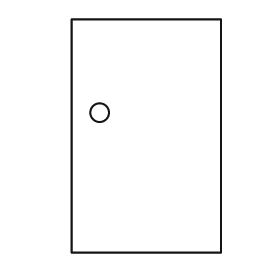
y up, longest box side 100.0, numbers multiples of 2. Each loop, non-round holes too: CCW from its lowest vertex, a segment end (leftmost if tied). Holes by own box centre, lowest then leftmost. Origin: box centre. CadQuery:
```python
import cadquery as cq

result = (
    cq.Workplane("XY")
    .moveTo(-32.0, -50.0)
    .lineTo(32.0, -50.0)
    .lineTo(32.0, 50.0)
    .lineTo(-32.0, 50.0)
    .close()
    .moveTo(-20.0, 10.0)
    .circle(4.0)
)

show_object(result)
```